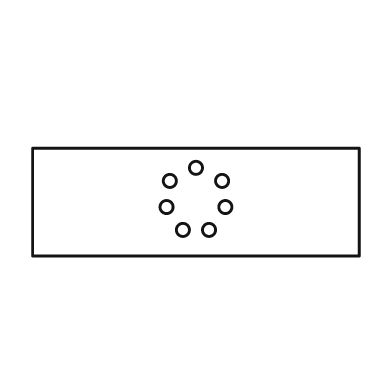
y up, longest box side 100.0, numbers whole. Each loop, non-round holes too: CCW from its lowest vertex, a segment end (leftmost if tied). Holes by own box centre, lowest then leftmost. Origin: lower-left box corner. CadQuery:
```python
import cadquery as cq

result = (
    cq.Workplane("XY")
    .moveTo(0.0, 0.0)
    .lineTo(100.0, 0.0)
    .lineTo(100.0, 33.0)
    .lineTo(0.0, 33.0)
    .close()
    .moveTo(46.0, 8.0)
    .circle(2.0)
    .moveTo(54.0, 8.0)
    .circle(2.0)
    .moveTo(41.0, 15.0)
    .circle(2.0)
    .moveTo(59.0, 15.0)
    .circle(2.0)
    .moveTo(42.0, 23.0)
    .circle(2.0)
    .moveTo(58.0, 23.0)
    .circle(2.0)
    .moveTo(50.0, 27.0)
    .circle(2.0)
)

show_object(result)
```